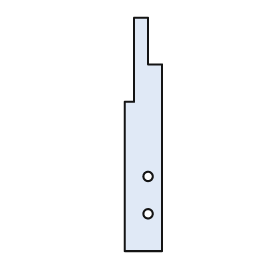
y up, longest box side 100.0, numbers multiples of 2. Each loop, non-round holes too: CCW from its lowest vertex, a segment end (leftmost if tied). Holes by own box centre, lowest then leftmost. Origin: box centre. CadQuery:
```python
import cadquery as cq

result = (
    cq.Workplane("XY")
    .moveTo(-8.0, -50.0)
    .lineTo(8.0, -50.0)
    .lineTo(8.0, 30.0)
    .lineTo(2.0, 30.0)
    .lineTo(2.0, 50.0)
    .lineTo(-4.0, 50.0)
    .lineTo(-4.0, 14.0)
    .lineTo(-8.0, 14.0)
    .close()
    .moveTo(2.0, -34.0)
    .circle(2.0)
    .moveTo(2.0, -18.0)
    .circle(2.0)
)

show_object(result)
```